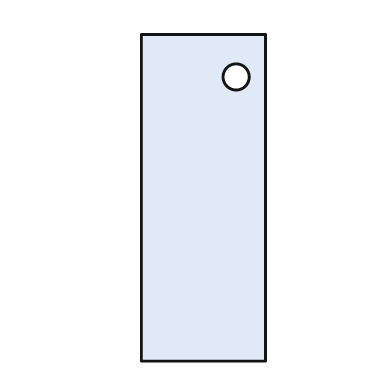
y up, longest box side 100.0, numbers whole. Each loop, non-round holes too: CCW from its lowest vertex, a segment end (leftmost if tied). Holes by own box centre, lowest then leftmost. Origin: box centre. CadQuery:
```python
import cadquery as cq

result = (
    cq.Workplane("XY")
    .moveTo(-19.0, -50.0)
    .lineTo(19.0, -50.0)
    .lineTo(19.0, 50.0)
    .lineTo(-19.0, 50.0)
    .close()
    .moveTo(10.0, 37.0)
    .circle(4.0)
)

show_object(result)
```